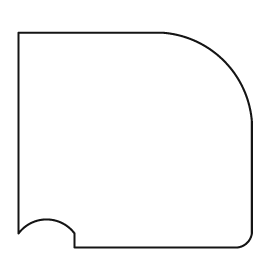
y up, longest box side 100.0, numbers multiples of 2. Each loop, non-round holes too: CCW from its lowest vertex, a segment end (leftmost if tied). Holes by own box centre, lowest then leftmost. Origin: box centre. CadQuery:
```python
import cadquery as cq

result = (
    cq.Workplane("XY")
    .moveTo(-26.0, -46.0)
    .lineTo(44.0, -46.0)
    .threePointArc((48.0, -44.0), (50.0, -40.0))
    .lineTo(50.0, 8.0)
    .threePointArc((38.0, 34.0), (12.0, 46.0))
    .lineTo(-50.0, 46.0)
    .lineTo(-50.0, -40.0)
    .threePointArc((-38.0, -34.0), (-26.0, -40.0))
    .close()
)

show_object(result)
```